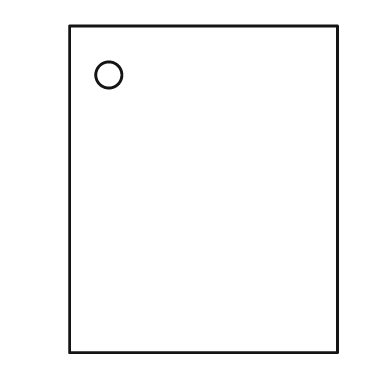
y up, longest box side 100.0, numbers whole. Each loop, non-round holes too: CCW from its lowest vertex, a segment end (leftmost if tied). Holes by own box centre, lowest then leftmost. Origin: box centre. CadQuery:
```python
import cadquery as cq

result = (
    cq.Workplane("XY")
    .moveTo(-41.0, -50.0)
    .lineTo(41.0, -50.0)
    .lineTo(41.0, 50.0)
    .lineTo(-41.0, 50.0)
    .close()
    .moveTo(-29.0, 35.0)
    .circle(4.0)
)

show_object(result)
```